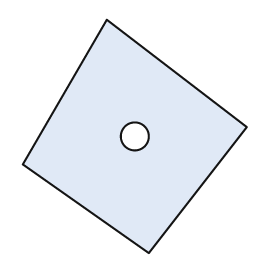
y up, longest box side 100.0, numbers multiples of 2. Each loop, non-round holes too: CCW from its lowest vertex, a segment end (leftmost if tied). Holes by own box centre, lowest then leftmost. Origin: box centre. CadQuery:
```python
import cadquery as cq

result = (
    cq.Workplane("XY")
    .moveTo(6.0, -50.0)
    .lineTo(48.0, 4.0)
    .lineTo(-12.0, 50.0)
    .lineTo(-48.0, -12.0)
    .close()
    .moveTo(0.0, 0.0)
    .circle(6.0)
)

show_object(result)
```